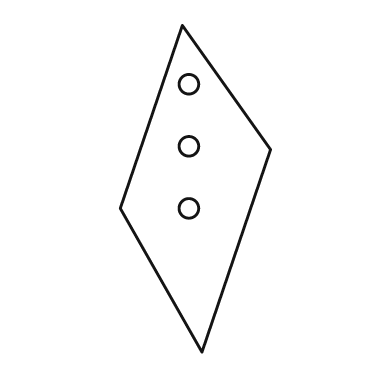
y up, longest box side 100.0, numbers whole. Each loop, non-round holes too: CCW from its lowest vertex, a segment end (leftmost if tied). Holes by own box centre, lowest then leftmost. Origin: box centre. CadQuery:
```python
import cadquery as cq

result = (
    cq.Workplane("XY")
    .moveTo(2.0, -50.0)
    .lineTo(23.0, 12.0)
    .lineTo(-4.0, 50.0)
    .lineTo(-23.0, -6.0)
    .close()
    .moveTo(-2.0, -6.0)
    .circle(3.0)
    .moveTo(-2.0, 13.0)
    .circle(3.0)
    .moveTo(-2.0, 32.0)
    .circle(3.0)
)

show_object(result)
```